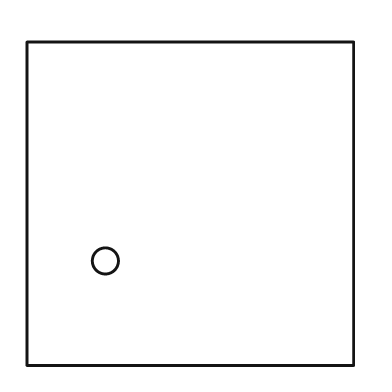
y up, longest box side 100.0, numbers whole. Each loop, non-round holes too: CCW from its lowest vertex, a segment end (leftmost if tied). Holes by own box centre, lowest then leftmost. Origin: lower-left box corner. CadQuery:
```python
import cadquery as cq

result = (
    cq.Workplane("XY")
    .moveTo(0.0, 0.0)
    .lineTo(100.0, 0.0)
    .lineTo(100.0, 99.0)
    .lineTo(0.0, 99.0)
    .close()
    .moveTo(24.0, 32.0)
    .circle(4.0)
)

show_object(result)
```